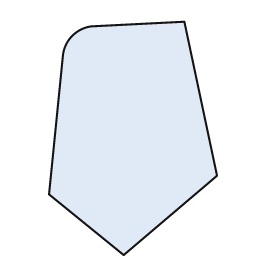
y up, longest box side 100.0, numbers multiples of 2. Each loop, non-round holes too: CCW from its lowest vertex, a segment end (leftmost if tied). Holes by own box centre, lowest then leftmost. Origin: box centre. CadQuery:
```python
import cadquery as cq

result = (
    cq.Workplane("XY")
    .moveTo(-4.0, -50.0)
    .lineTo(36.0, -16.0)
    .lineTo(22.0, 50.0)
    .lineTo(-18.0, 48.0)
    .threePointArc((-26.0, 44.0), (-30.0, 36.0))
    .lineTo(-36.0, -24.0)
    .close()
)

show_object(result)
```